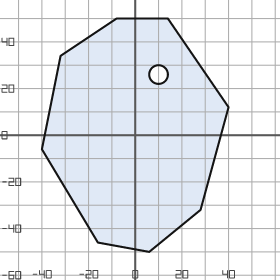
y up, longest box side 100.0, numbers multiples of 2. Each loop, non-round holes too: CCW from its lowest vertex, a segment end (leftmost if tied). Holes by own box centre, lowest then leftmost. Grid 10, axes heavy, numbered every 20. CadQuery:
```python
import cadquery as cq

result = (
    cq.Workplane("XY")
    .moveTo(6.0, -50.0)
    .lineTo(28.0, -32.0)
    .lineTo(40.0, 12.0)
    .lineTo(14.0, 50.0)
    .lineTo(-8.0, 50.0)
    .lineTo(-32.0, 34.0)
    .lineTo(-40.0, -6.0)
    .lineTo(-16.0, -46.0)
    .close()
    .moveTo(10.0, 26.0)
    .circle(4.0)
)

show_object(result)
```